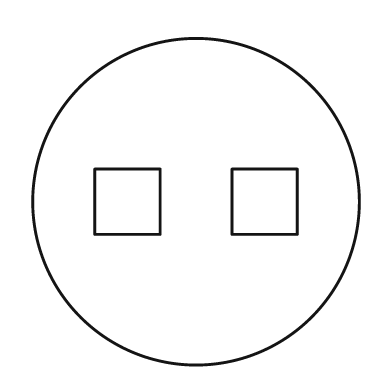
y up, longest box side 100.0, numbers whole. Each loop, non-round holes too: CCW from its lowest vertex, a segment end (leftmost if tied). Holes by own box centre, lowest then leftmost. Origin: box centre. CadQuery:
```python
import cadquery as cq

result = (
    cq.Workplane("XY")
    .moveTo(0.0, 0.0)
    .circle(50.0)
    .moveTo(-31.0, -10.0)
    .lineTo(-11.0, -10.0)
    .lineTo(-11.0, 10.0)
    .lineTo(-31.0, 10.0)
    .close()
    .moveTo(11.0, -10.0)
    .lineTo(31.0, -10.0)
    .lineTo(31.0, 10.0)
    .lineTo(11.0, 10.0)
    .close()
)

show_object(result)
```